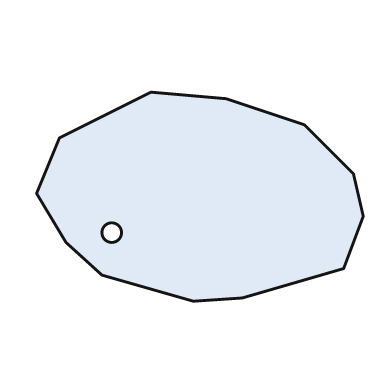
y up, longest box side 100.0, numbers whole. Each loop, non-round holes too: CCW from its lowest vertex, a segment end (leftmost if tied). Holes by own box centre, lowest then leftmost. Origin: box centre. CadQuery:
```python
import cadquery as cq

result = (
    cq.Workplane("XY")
    .moveTo(-2.0, -32.0)
    .lineTo(13.0, -31.0)
    .lineTo(44.0, -22.0)
    .lineTo(50.0, -6.0)
    .lineTo(47.0, 7.0)
    .lineTo(32.0, 22.0)
    .lineTo(8.0, 30.0)
    .lineTo(-15.0, 32.0)
    .lineTo(-43.0, 18.0)
    .lineTo(-50.0, 1.0)
    .lineTo(-41.0, -14.0)
    .lineTo(-30.0, -24.0)
    .close()
    .moveTo(-27.0, -11.0)
    .circle(3.0)
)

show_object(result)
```